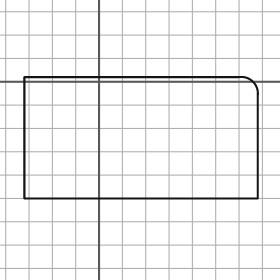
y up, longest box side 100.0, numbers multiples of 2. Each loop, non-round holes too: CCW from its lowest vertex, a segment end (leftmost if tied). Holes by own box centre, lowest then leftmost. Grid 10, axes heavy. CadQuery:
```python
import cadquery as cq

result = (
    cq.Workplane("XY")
    .moveTo(-32.0, -50.0)
    .lineTo(68.0, -50.0)
    .lineTo(68.0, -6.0)
    .threePointArc((66.0, 0.0), (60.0, 2.0))
    .lineTo(-32.0, 2.0)
    .close()
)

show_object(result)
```